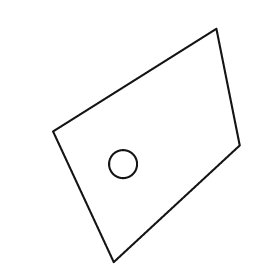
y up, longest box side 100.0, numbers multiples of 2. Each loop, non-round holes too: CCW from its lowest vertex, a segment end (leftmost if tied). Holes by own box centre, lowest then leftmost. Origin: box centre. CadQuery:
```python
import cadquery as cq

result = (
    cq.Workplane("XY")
    .moveTo(-14.0, -50.0)
    .lineTo(40.0, 0.0)
    .lineTo(30.0, 50.0)
    .lineTo(-40.0, 6.0)
    .close()
    .moveTo(-10.0, -8.0)
    .circle(6.0)
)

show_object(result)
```